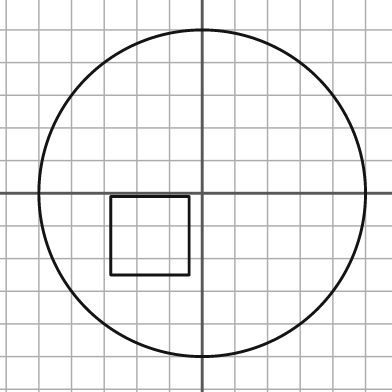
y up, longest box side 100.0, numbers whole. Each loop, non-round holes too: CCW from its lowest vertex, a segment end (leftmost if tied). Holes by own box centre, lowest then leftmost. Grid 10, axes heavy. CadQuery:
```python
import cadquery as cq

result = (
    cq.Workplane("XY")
    .moveTo(0.0, 0.0)
    .circle(50.0)
    .moveTo(-28.0, -25.0)
    .lineTo(-4.0, -25.0)
    .lineTo(-4.0, -1.0)
    .lineTo(-28.0, -1.0)
    .close()
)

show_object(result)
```